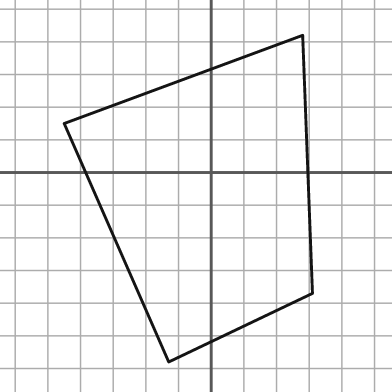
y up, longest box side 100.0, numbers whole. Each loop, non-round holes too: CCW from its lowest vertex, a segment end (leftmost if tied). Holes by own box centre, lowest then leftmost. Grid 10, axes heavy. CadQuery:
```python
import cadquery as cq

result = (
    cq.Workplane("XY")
    .moveTo(-13.0, -58.0)
    .lineTo(31.0, -37.0)
    .lineTo(28.0, 42.0)
    .lineTo(-45.0, 15.0)
    .close()
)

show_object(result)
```